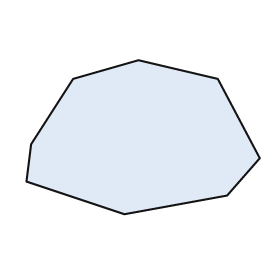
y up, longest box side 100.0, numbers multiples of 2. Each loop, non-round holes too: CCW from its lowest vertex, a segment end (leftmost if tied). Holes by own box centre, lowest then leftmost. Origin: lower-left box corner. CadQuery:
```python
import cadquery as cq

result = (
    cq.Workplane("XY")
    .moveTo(42.0, 0.0)
    .lineTo(86.0, 8.0)
    .lineTo(100.0, 24.0)
    .lineTo(82.0, 58.0)
    .lineTo(48.0, 66.0)
    .lineTo(20.0, 58.0)
    .lineTo(2.0, 30.0)
    .lineTo(0.0, 14.0)
    .close()
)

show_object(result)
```